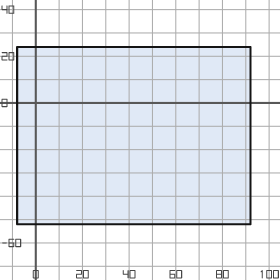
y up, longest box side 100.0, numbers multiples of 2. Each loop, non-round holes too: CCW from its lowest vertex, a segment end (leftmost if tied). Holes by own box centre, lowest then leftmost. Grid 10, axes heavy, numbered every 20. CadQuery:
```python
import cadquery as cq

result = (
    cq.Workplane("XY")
    .moveTo(-8.0, -52.0)
    .lineTo(92.0, -52.0)
    .lineTo(92.0, 24.0)
    .lineTo(-8.0, 24.0)
    .close()
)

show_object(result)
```